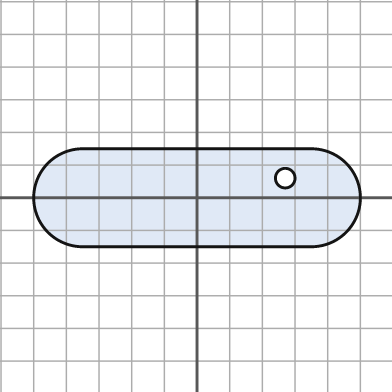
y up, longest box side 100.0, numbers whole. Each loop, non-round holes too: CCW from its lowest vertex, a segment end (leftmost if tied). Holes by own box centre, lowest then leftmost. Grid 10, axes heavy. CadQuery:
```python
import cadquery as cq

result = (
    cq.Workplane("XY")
    .moveTo(-35.0, -15.0)
    .lineTo(35.0, -15.0)
    .threePointArc((50.0, 0.0), (35.0, 15.0))
    .lineTo(-35.0, 15.0)
    .threePointArc((-50.0, 0.0), (-35.0, -15.0))
    .close()
    .moveTo(27.0, 6.0)
    .circle(3.0)
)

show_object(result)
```